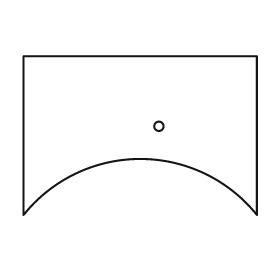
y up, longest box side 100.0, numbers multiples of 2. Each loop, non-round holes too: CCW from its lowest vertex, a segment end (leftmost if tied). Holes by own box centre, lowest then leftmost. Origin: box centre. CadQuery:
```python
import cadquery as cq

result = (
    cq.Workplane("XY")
    .moveTo(-50.0, -34.0)
    .threePointArc((0.0, -10.0), (50.0, -34.0))
    .lineTo(50.0, 34.0)
    .lineTo(-50.0, 34.0)
    .close()
    .moveTo(8.0, 4.0)
    .circle(2.0)
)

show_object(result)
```